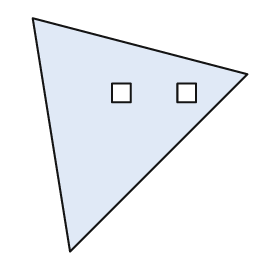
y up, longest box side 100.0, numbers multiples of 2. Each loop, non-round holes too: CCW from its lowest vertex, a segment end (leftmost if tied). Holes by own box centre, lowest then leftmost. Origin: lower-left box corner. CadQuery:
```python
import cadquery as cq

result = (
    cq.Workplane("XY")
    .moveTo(16.0, 0.0)
    .lineTo(92.0, 76.0)
    .lineTo(0.0, 100.0)
    .close()
    .moveTo(34.0, 64.0)
    .lineTo(42.0, 64.0)
    .lineTo(42.0, 72.0)
    .lineTo(34.0, 72.0)
    .close()
    .moveTo(62.0, 64.0)
    .lineTo(70.0, 64.0)
    .lineTo(70.0, 72.0)
    .lineTo(62.0, 72.0)
    .close()
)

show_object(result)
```